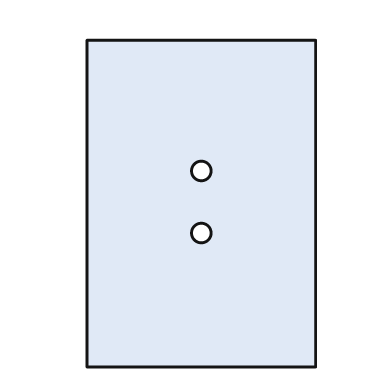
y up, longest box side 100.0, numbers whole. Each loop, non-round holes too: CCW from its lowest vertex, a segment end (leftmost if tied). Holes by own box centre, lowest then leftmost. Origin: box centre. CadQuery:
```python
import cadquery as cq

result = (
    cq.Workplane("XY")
    .moveTo(-35.0, -50.0)
    .lineTo(35.0, -50.0)
    .lineTo(35.0, 50.0)
    .lineTo(-35.0, 50.0)
    .close()
    .moveTo(0.0, -9.0)
    .circle(3.0)
    .moveTo(0.0, 10.0)
    .circle(3.0)
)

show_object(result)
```